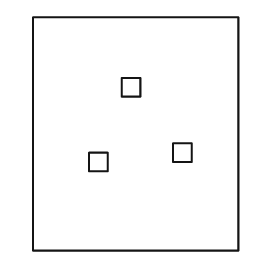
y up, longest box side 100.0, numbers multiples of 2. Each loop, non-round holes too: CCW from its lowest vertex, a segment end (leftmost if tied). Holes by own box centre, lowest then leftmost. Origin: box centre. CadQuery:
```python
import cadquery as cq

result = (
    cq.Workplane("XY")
    .moveTo(-44.0, -50.0)
    .lineTo(44.0, -50.0)
    .lineTo(44.0, 50.0)
    .lineTo(-44.0, 50.0)
    .close()
    .moveTo(-20.0, -16.0)
    .lineTo(-12.0, -16.0)
    .lineTo(-12.0, -8.0)
    .lineTo(-20.0, -8.0)
    .close()
    .moveTo(16.0, -12.0)
    .lineTo(24.0, -12.0)
    .lineTo(24.0, -4.0)
    .lineTo(16.0, -4.0)
    .close()
    .moveTo(-6.0, 16.0)
    .lineTo(2.0, 16.0)
    .lineTo(2.0, 24.0)
    .lineTo(-6.0, 24.0)
    .close()
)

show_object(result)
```